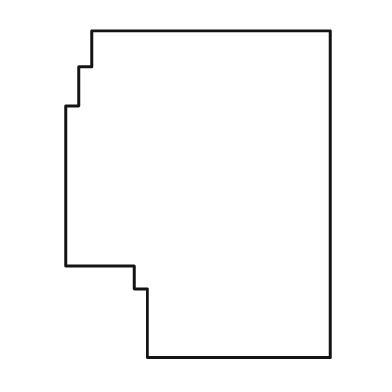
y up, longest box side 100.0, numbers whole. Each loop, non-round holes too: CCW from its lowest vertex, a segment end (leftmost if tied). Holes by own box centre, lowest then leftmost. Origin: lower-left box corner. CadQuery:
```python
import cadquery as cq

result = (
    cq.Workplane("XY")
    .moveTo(25.0, 0.0)
    .lineTo(81.0, 0.0)
    .lineTo(81.0, 100.0)
    .lineTo(8.0, 100.0)
    .lineTo(8.0, 89.0)
    .lineTo(4.0, 89.0)
    .lineTo(4.0, 77.0)
    .lineTo(0.0, 77.0)
    .lineTo(0.0, 28.0)
    .lineTo(21.0, 28.0)
    .lineTo(21.0, 21.0)
    .lineTo(25.0, 21.0)
    .close()
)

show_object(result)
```